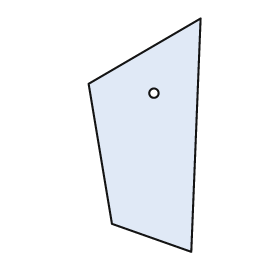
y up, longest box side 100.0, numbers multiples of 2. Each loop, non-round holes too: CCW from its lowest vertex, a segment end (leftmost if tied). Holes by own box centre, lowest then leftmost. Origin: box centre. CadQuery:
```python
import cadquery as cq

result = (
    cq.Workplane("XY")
    .moveTo(20.0, -50.0)
    .lineTo(24.0, 50.0)
    .lineTo(-24.0, 22.0)
    .lineTo(-14.0, -38.0)
    .close()
    .moveTo(4.0, 18.0)
    .circle(2.0)
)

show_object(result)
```